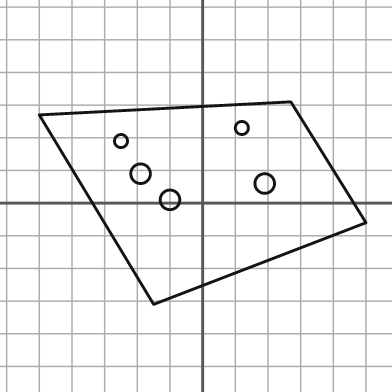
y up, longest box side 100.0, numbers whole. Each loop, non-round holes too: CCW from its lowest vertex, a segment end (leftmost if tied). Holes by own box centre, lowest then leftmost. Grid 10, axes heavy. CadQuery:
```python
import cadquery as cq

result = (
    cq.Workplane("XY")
    .moveTo(-15.0, -31.0)
    .lineTo(50.0, -6.0)
    .lineTo(27.0, 31.0)
    .lineTo(-50.0, 27.0)
    .close()
    .moveTo(-10.0, 1.0)
    .circle(3.0)
    .moveTo(19.0, 6.0)
    .circle(3.0)
    .moveTo(-19.0, 9.0)
    .circle(3.0)
    .moveTo(-25.0, 19.0)
    .circle(2.0)
    .moveTo(12.0, 23.0)
    .circle(2.0)
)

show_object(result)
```